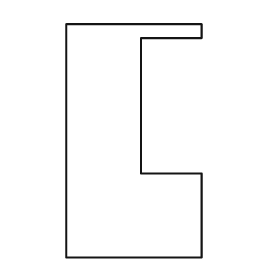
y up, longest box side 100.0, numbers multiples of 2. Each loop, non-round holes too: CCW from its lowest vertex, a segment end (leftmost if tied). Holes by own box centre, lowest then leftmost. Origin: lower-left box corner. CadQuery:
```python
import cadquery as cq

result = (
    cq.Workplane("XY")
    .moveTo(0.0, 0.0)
    .lineTo(58.0, 0.0)
    .lineTo(58.0, 36.0)
    .lineTo(32.0, 36.0)
    .lineTo(32.0, 94.0)
    .lineTo(58.0, 94.0)
    .lineTo(58.0, 100.0)
    .lineTo(0.0, 100.0)
    .close()
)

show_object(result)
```